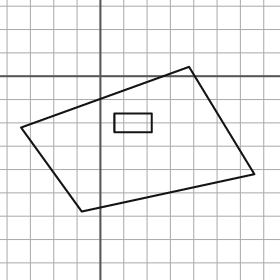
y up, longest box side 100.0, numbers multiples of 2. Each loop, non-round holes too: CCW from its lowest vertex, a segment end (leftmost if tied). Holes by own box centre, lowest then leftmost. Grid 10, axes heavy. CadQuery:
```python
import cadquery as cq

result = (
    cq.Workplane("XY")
    .moveTo(-8.0, -58.0)
    .lineTo(66.0, -42.0)
    .lineTo(38.0, 4.0)
    .lineTo(-34.0, -22.0)
    .close()
    .moveTo(6.0, -24.0)
    .lineTo(22.0, -24.0)
    .lineTo(22.0, -16.0)
    .lineTo(6.0, -16.0)
    .close()
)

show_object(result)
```